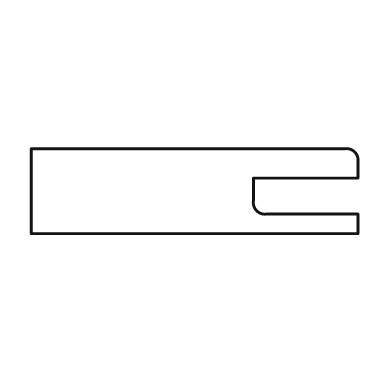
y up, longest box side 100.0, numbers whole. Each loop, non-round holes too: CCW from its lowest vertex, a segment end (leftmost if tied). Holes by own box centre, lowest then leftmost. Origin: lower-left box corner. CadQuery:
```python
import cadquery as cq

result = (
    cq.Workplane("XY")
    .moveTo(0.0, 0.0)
    .lineTo(100.0, 0.0)
    .lineTo(100.0, 6.0)
    .lineTo(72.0, 6.0)
    .threePointArc((69.0, 7.0), (68.0, 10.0))
    .lineTo(68.0, 17.0)
    .lineTo(100.0, 17.0)
    .lineTo(100.0, 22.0)
    .threePointArc((99.0, 25.0), (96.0, 26.0))
    .lineTo(0.0, 26.0)
    .close()
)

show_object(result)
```